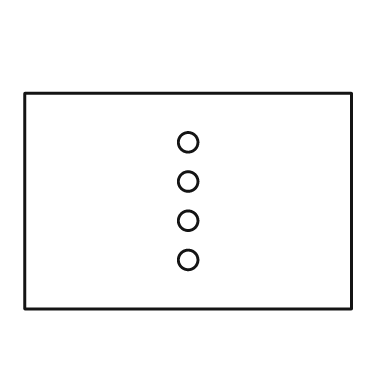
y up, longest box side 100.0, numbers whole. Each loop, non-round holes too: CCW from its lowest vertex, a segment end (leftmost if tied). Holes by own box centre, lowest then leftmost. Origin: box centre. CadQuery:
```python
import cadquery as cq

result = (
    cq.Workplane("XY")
    .moveTo(-50.0, -33.0)
    .lineTo(50.0, -33.0)
    .lineTo(50.0, 33.0)
    .lineTo(-50.0, 33.0)
    .close()
    .moveTo(0.0, -18.0)
    .circle(3.0)
    .moveTo(0.0, -6.0)
    .circle(3.0)
    .moveTo(0.0, 6.0)
    .circle(3.0)
    .moveTo(0.0, 18.0)
    .circle(3.0)
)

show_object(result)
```